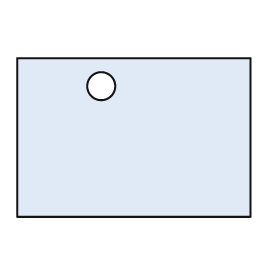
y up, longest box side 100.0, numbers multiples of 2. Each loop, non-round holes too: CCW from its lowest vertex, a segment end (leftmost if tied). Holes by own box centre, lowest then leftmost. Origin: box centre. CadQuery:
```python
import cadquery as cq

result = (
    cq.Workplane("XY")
    .moveTo(-50.0, -34.0)
    .lineTo(50.0, -34.0)
    .lineTo(50.0, 34.0)
    .lineTo(-50.0, 34.0)
    .close()
    .moveTo(-14.0, 22.0)
    .circle(6.0)
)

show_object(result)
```